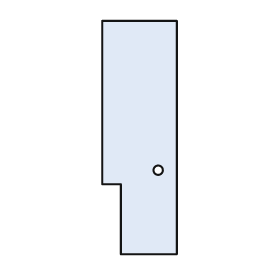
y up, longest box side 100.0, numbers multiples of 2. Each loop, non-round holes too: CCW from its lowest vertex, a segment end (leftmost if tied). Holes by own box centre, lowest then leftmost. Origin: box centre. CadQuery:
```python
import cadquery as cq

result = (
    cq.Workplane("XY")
    .moveTo(-8.0, -50.0)
    .lineTo(16.0, -50.0)
    .lineTo(16.0, 50.0)
    .lineTo(-16.0, 50.0)
    .lineTo(-16.0, -20.0)
    .lineTo(-8.0, -20.0)
    .close()
    .moveTo(8.0, -14.0)
    .circle(2.0)
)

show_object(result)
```